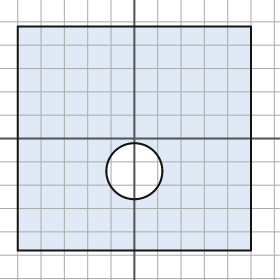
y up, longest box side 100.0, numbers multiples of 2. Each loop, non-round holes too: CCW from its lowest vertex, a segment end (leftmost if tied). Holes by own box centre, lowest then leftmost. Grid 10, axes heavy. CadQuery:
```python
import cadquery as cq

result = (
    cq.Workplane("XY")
    .moveTo(-50.0, -48.0)
    .lineTo(50.0, -48.0)
    .lineTo(50.0, 48.0)
    .lineTo(-50.0, 48.0)
    .close()
    .moveTo(0.0, -14.0)
    .circle(12.0)
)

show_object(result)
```